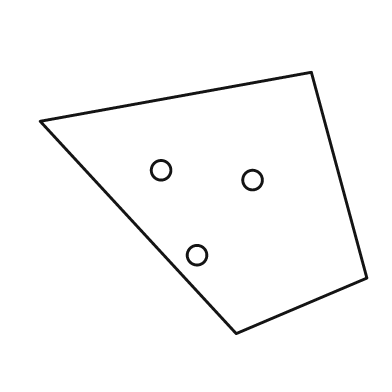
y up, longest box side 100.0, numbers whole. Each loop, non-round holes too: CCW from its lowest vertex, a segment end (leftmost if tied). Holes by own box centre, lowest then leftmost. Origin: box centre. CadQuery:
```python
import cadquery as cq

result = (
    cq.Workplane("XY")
    .moveTo(10.0, -40.0)
    .lineTo(50.0, -23.0)
    .lineTo(33.0, 40.0)
    .lineTo(-50.0, 25.0)
    .close()
    .moveTo(-2.0, -16.0)
    .circle(3.0)
    .moveTo(15.0, 7.0)
    .circle(3.0)
    .moveTo(-13.0, 10.0)
    .circle(3.0)
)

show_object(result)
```